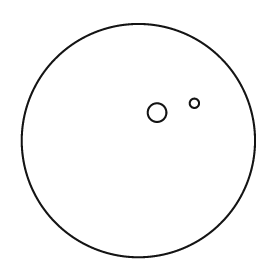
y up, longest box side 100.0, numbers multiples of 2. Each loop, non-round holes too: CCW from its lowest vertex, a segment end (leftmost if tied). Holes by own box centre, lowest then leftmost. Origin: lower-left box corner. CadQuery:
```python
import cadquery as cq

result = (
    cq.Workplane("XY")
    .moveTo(50.0, 50.0)
    .circle(50.0)
    .moveTo(58.0, 62.0)
    .circle(4.0)
    .moveTo(74.0, 66.0)
    .circle(2.0)
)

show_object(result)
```